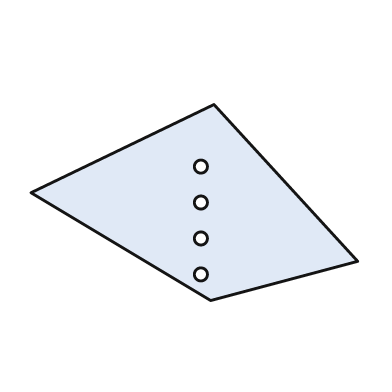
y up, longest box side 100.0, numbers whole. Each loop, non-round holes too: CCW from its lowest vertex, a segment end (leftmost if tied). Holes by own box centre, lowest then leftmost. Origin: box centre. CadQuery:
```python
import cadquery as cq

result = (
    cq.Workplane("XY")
    .moveTo(5.0, -30.0)
    .lineTo(50.0, -18.0)
    .lineTo(6.0, 30.0)
    .lineTo(-50.0, 3.0)
    .close()
    .moveTo(2.0, -22.0)
    .circle(2.0)
    .moveTo(2.0, -11.0)
    .circle(2.0)
    .moveTo(2.0, 0.0)
    .circle(2.0)
    .moveTo(2.0, 11.0)
    .circle(2.0)
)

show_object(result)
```